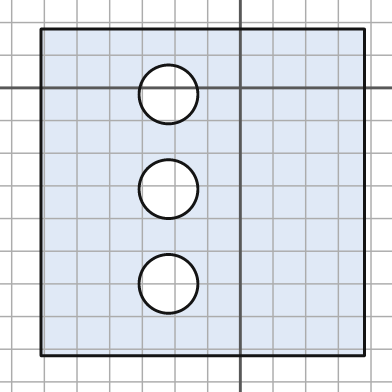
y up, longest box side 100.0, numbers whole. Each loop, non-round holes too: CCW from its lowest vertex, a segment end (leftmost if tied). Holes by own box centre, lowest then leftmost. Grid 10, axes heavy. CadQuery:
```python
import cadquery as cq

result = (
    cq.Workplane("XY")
    .moveTo(-61.0, -82.0)
    .lineTo(38.0, -82.0)
    .lineTo(38.0, 18.0)
    .lineTo(-61.0, 18.0)
    .close()
    .moveTo(-22.0, -60.0)
    .circle(9.0)
    .moveTo(-22.0, -31.0)
    .circle(9.0)
    .moveTo(-22.0, -2.0)
    .circle(9.0)
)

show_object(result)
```